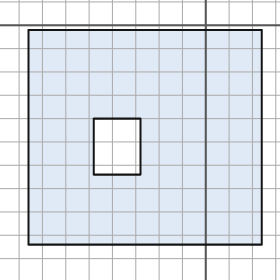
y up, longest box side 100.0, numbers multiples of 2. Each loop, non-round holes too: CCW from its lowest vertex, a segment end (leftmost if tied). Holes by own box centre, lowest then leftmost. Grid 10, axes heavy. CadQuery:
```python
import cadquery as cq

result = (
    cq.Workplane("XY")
    .moveTo(-76.0, -94.0)
    .lineTo(24.0, -94.0)
    .lineTo(24.0, -2.0)
    .lineTo(-76.0, -2.0)
    .close()
    .moveTo(-48.0, -64.0)
    .lineTo(-28.0, -64.0)
    .lineTo(-28.0, -40.0)
    .lineTo(-48.0, -40.0)
    .close()
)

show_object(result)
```